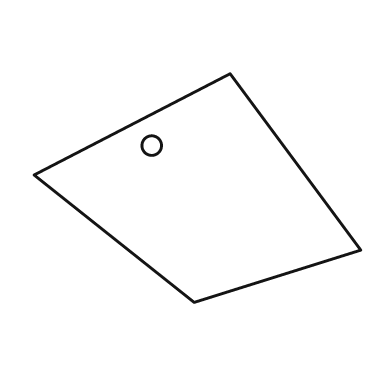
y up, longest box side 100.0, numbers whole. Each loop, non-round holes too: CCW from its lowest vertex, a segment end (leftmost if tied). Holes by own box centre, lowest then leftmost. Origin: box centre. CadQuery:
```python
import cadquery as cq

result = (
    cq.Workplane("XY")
    .moveTo(-1.0, -35.0)
    .lineTo(50.0, -19.0)
    .lineTo(10.0, 35.0)
    .lineTo(-50.0, 4.0)
    .close()
    .moveTo(-14.0, 13.0)
    .circle(3.0)
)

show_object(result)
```